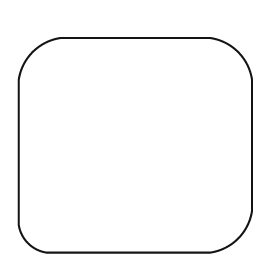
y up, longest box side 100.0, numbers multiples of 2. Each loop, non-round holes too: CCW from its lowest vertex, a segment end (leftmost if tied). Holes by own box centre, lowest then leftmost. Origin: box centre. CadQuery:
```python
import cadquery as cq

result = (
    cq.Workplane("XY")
    .moveTo(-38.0, -46.0)
    .lineTo(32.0, -46.0)
    .threePointArc((44.0, -40.0), (50.0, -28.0))
    .lineTo(50.0, 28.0)
    .threePointArc((44.0, 40.0), (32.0, 46.0))
    .lineTo(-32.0, 46.0)
    .threePointArc((-44.0, 40.0), (-50.0, 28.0))
    .lineTo(-50.0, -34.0)
    .threePointArc((-46.0, -42.0), (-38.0, -46.0))
    .close()
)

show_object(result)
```